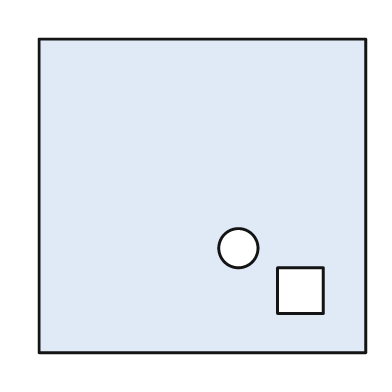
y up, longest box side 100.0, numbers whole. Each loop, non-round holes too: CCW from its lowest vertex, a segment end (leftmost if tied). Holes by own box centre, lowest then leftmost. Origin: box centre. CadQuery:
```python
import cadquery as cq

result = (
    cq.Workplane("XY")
    .moveTo(-50.0, -48.0)
    .lineTo(50.0, -48.0)
    .lineTo(50.0, 48.0)
    .lineTo(-50.0, 48.0)
    .close()
    .moveTo(23.0, -36.0)
    .lineTo(37.0, -36.0)
    .lineTo(37.0, -22.0)
    .lineTo(23.0, -22.0)
    .close()
    .moveTo(11.0, -16.0)
    .circle(6.0)
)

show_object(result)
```